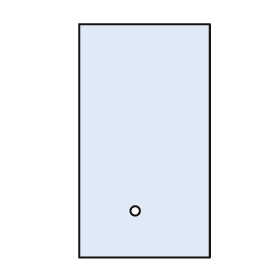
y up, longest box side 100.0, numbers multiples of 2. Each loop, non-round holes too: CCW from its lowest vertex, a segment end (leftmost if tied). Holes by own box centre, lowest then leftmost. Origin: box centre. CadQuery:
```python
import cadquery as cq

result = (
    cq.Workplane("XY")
    .moveTo(-28.0, -50.0)
    .lineTo(28.0, -50.0)
    .lineTo(28.0, 50.0)
    .lineTo(-28.0, 50.0)
    .close()
    .moveTo(-4.0, -30.0)
    .circle(2.0)
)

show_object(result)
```